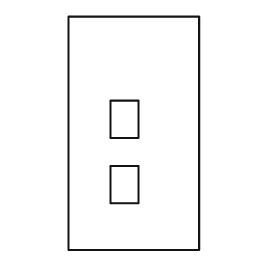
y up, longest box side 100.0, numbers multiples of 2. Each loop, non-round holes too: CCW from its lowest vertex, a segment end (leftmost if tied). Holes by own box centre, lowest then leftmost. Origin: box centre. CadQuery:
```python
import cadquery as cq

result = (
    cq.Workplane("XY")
    .moveTo(-28.0, -50.0)
    .lineTo(28.0, -50.0)
    .lineTo(28.0, 50.0)
    .lineTo(-28.0, 50.0)
    .close()
    .moveTo(-10.0, -30.0)
    .lineTo(2.0, -30.0)
    .lineTo(2.0, -14.0)
    .lineTo(-10.0, -14.0)
    .close()
    .moveTo(-10.0, -2.0)
    .lineTo(2.0, -2.0)
    .lineTo(2.0, 14.0)
    .lineTo(-10.0, 14.0)
    .close()
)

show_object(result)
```